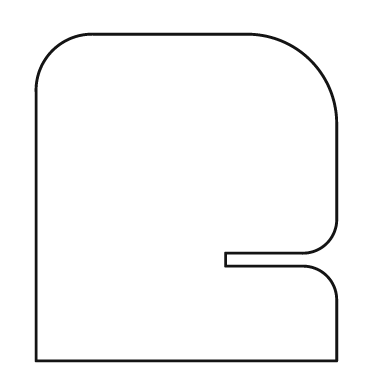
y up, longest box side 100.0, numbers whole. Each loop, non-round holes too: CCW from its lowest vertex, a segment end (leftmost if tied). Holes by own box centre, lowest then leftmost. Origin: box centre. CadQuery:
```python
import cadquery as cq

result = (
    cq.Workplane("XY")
    .moveTo(-46.0, -50.0)
    .lineTo(46.0, -50.0)
    .lineTo(46.0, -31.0)
    .threePointArc((43.0, -24.0), (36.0, -21.0))
    .lineTo(12.0, -21.0)
    .lineTo(12.0, -17.0)
    .lineTo(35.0, -17.0)
    .threePointArc((43.0, -14.0), (46.0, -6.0))
    .lineTo(46.0, 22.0)
    .threePointArc((38.0, 42.0), (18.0, 50.0))
    .lineTo(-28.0, 50.0)
    .threePointArc((-41.0, 45.0), (-46.0, 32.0))
    .close()
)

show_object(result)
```